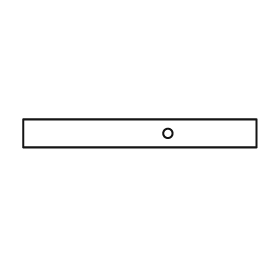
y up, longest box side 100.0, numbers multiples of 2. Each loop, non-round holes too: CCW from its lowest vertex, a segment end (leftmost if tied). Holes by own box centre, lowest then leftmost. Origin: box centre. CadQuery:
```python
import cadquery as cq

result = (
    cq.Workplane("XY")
    .moveTo(-50.0, -6.0)
    .lineTo(50.0, -6.0)
    .lineTo(50.0, 6.0)
    .lineTo(-50.0, 6.0)
    .close()
    .moveTo(12.0, 0.0)
    .circle(2.0)
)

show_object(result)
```